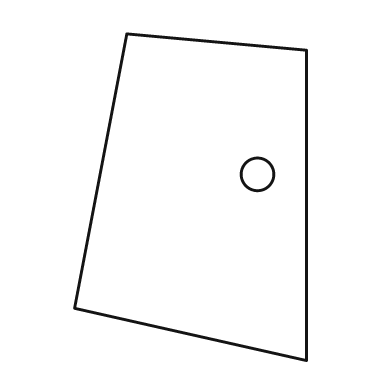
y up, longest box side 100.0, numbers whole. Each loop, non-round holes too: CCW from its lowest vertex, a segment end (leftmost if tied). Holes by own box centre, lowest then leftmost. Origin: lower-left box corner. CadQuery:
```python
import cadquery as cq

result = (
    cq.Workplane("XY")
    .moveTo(71.0, 0.0)
    .lineTo(71.0, 95.0)
    .lineTo(16.0, 100.0)
    .lineTo(0.0, 16.0)
    .close()
    .moveTo(56.0, 57.0)
    .circle(5.0)
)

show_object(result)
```